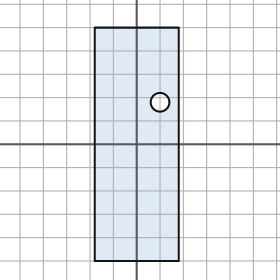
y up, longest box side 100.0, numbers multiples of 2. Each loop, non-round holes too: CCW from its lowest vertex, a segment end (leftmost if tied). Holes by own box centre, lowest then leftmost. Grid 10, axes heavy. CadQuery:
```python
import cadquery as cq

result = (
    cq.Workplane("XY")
    .moveTo(-18.0, -50.0)
    .lineTo(18.0, -50.0)
    .lineTo(18.0, 50.0)
    .lineTo(-18.0, 50.0)
    .close()
    .moveTo(10.0, 18.0)
    .circle(4.0)
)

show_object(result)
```